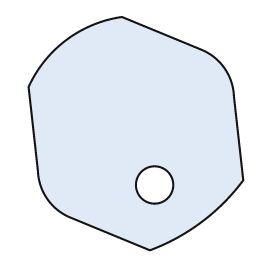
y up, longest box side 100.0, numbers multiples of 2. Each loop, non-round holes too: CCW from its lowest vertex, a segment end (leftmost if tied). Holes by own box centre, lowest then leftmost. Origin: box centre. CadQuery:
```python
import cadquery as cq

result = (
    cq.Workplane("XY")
    .moveTo(6.0, -50.0)
    .threePointArc((28.0, -38.0), (46.0, -20.0))
    .lineTo(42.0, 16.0)
    .threePointArc((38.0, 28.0), (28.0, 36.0))
    .lineTo(-6.0, 50.0)
    .threePointArc((-30.0, 40.0), (-46.0, 20.0))
    .lineTo(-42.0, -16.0)
    .threePointArc((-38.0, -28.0), (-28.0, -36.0))
    .close()
    .moveTo(8.0, -22.0)
    .circle(8.0)
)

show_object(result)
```